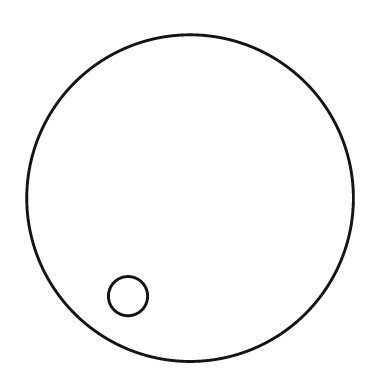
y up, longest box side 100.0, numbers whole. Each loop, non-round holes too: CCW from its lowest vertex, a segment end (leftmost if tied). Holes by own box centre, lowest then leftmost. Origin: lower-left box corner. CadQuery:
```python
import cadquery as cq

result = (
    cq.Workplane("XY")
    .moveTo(50.0, 50.0)
    .circle(50.0)
    .moveTo(31.0, 20.0)
    .circle(6.0)
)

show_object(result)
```